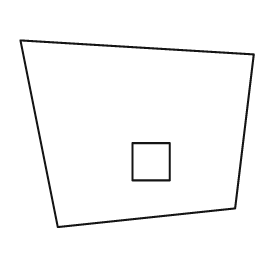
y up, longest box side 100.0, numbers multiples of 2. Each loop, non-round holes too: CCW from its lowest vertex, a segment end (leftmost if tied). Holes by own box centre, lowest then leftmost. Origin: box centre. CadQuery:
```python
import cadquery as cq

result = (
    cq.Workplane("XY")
    .moveTo(-34.0, -40.0)
    .lineTo(42.0, -32.0)
    .lineTo(50.0, 34.0)
    .lineTo(-50.0, 40.0)
    .close()
    .moveTo(-2.0, -20.0)
    .lineTo(14.0, -20.0)
    .lineTo(14.0, -4.0)
    .lineTo(-2.0, -4.0)
    .close()
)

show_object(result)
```